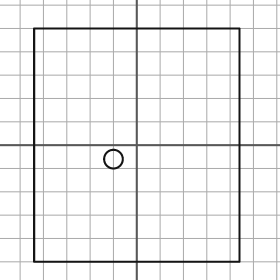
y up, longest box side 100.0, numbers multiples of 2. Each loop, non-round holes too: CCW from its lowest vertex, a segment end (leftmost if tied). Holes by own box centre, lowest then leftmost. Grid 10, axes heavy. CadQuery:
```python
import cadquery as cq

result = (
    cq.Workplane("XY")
    .moveTo(-44.0, -50.0)
    .lineTo(44.0, -50.0)
    .lineTo(44.0, 50.0)
    .lineTo(-44.0, 50.0)
    .close()
    .moveTo(-10.0, -6.0)
    .circle(4.0)
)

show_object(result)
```